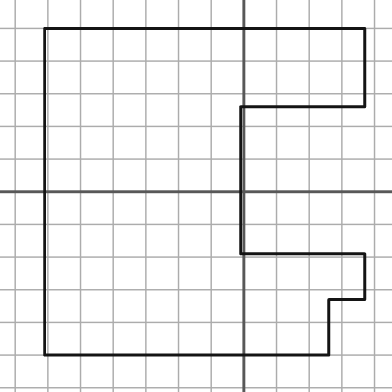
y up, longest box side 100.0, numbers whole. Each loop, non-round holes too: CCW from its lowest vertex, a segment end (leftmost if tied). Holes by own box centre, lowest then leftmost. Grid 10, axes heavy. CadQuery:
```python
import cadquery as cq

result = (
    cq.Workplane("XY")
    .moveTo(-61.0, -50.0)
    .lineTo(26.0, -50.0)
    .lineTo(26.0, -33.0)
    .lineTo(37.0, -33.0)
    .lineTo(37.0, -19.0)
    .lineTo(-1.0, -19.0)
    .lineTo(-1.0, 26.0)
    .lineTo(37.0, 26.0)
    .lineTo(37.0, 50.0)
    .lineTo(-61.0, 50.0)
    .close()
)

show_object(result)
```